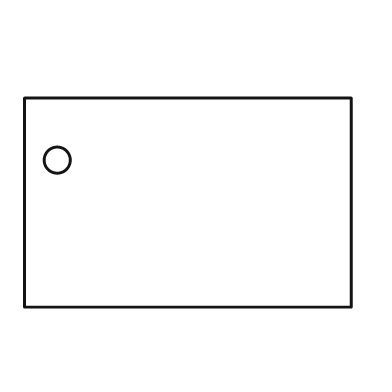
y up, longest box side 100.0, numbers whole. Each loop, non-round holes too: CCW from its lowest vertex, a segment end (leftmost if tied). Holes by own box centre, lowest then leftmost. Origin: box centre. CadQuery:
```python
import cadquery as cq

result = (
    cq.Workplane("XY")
    .moveTo(-50.0, -32.0)
    .lineTo(50.0, -32.0)
    .lineTo(50.0, 32.0)
    .lineTo(-50.0, 32.0)
    .close()
    .moveTo(-40.0, 13.0)
    .circle(4.0)
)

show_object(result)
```